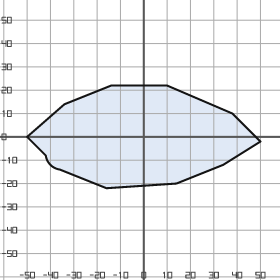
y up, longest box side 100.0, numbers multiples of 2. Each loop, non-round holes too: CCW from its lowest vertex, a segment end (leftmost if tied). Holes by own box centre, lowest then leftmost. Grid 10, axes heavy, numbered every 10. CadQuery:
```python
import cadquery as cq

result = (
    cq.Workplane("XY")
    .moveTo(-16.0, -22.0)
    .lineTo(14.0, -20.0)
    .lineTo(34.0, -12.0)
    .lineTo(50.0, -2.0)
    .lineTo(38.0, 10.0)
    .lineTo(10.0, 22.0)
    .lineTo(-14.0, 22.0)
    .lineTo(-34.0, 14.0)
    .lineTo(-50.0, 0.0)
    .lineTo(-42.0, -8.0)
    .threePointArc((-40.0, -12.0), (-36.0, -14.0))
    .close()
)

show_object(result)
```